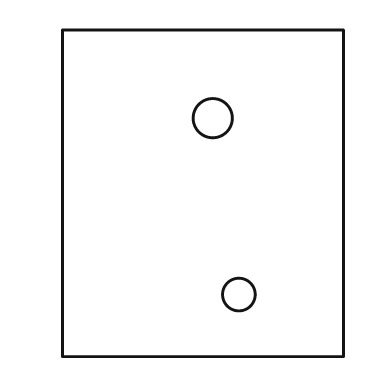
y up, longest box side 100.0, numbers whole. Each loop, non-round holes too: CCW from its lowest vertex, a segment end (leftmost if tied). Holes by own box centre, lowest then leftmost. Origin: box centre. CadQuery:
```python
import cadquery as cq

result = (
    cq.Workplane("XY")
    .moveTo(-43.0, -50.0)
    .lineTo(43.0, -50.0)
    .lineTo(43.0, 50.0)
    .lineTo(-43.0, 50.0)
    .close()
    .moveTo(11.0, -31.0)
    .circle(5.0)
    .moveTo(3.0, 23.0)
    .circle(6.0)
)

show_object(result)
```